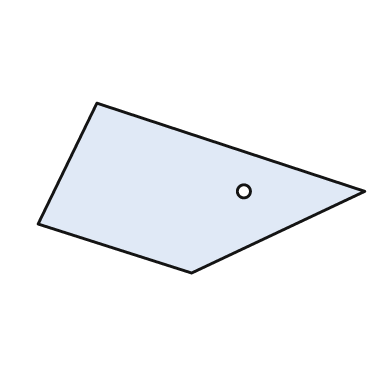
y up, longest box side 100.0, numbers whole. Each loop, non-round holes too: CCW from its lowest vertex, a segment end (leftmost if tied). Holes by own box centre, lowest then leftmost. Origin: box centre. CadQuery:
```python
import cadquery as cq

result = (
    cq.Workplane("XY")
    .moveTo(-3.0, -26.0)
    .lineTo(50.0, -1.0)
    .lineTo(-32.0, 26.0)
    .lineTo(-50.0, -11.0)
    .close()
    .moveTo(13.0, -1.0)
    .circle(2.0)
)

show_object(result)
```